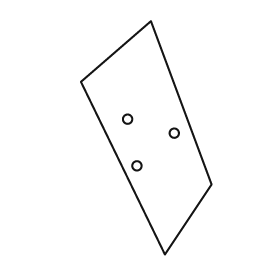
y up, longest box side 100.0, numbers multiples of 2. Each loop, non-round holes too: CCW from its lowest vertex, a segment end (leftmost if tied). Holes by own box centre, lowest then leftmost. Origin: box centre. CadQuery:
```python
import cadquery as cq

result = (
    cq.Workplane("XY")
    .moveTo(8.0, -50.0)
    .lineTo(28.0, -20.0)
    .lineTo(2.0, 50.0)
    .lineTo(-28.0, 24.0)
    .close()
    .moveTo(-4.0, -12.0)
    .circle(2.0)
    .moveTo(12.0, 2.0)
    .circle(2.0)
    .moveTo(-8.0, 8.0)
    .circle(2.0)
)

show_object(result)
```